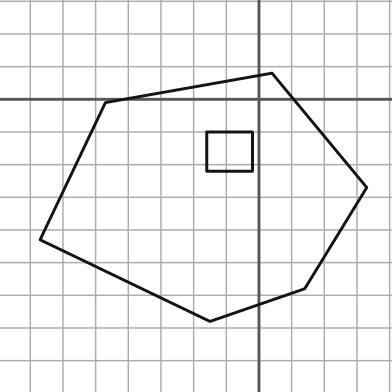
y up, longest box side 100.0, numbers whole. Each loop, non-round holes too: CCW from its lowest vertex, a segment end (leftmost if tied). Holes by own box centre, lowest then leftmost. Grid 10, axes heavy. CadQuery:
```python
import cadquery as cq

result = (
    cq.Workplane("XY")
    .moveTo(-15.0, -68.0)
    .lineTo(14.0, -58.0)
    .lineTo(33.0, -27.0)
    .lineTo(4.0, 8.0)
    .lineTo(-47.0, -1.0)
    .lineTo(-67.0, -43.0)
    .close()
    .moveTo(-16.0, -22.0)
    .lineTo(-2.0, -22.0)
    .lineTo(-2.0, -10.0)
    .lineTo(-16.0, -10.0)
    .close()
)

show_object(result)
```